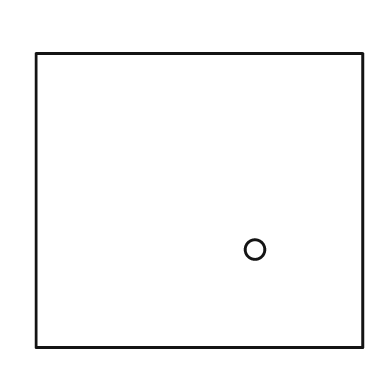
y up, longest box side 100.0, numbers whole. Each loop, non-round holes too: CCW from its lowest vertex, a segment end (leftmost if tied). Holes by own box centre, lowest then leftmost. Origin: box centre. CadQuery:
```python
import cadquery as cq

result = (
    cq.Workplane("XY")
    .moveTo(-50.0, -45.0)
    .lineTo(50.0, -45.0)
    .lineTo(50.0, 45.0)
    .lineTo(-50.0, 45.0)
    .close()
    .moveTo(17.0, -15.0)
    .circle(3.0)
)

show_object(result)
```